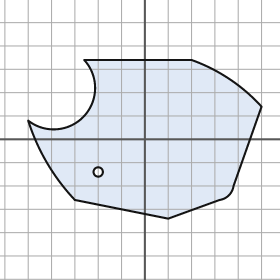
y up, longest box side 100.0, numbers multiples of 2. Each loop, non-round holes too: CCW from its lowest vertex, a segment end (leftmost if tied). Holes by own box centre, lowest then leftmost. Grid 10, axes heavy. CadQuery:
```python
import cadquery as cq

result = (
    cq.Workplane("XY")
    .moveTo(10.0, -34.0)
    .lineTo(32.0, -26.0)
    .threePointArc((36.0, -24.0), (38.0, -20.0))
    .lineTo(50.0, 14.0)
    .threePointArc((36.0, 26.0), (20.0, 34.0))
    .lineTo(-26.0, 34.0)
    .threePointArc((-26.0, 10.0), (-50.0, 8.0))
    .threePointArc((-42.0, -10.0), (-30.0, -26.0))
    .close()
    .moveTo(-20.0, -14.0)
    .circle(2.0)
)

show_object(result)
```